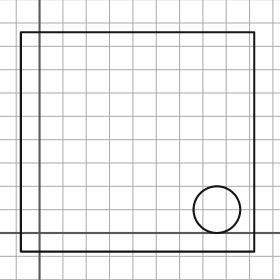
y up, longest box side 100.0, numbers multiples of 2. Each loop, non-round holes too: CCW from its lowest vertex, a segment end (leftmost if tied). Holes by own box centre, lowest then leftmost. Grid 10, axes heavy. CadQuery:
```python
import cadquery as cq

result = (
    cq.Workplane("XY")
    .moveTo(-8.0, -8.0)
    .lineTo(92.0, -8.0)
    .lineTo(92.0, 86.0)
    .lineTo(-8.0, 86.0)
    .close()
    .moveTo(76.0, 10.0)
    .circle(10.0)
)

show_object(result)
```